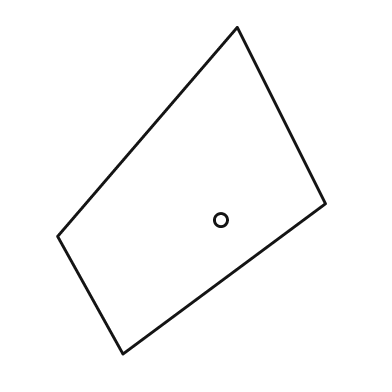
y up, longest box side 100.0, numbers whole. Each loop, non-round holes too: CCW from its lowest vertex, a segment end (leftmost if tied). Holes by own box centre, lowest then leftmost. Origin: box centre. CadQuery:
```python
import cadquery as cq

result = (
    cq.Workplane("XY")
    .moveTo(-21.0, -50.0)
    .lineTo(41.0, -4.0)
    .lineTo(14.0, 50.0)
    .lineTo(-41.0, -14.0)
    .close()
    .moveTo(9.0, -9.0)
    .circle(2.0)
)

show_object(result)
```